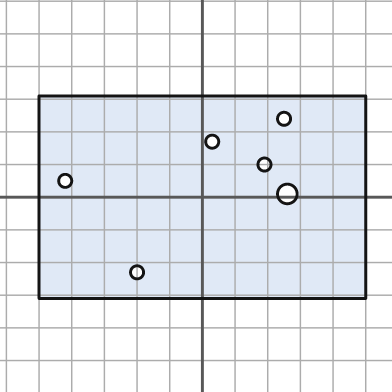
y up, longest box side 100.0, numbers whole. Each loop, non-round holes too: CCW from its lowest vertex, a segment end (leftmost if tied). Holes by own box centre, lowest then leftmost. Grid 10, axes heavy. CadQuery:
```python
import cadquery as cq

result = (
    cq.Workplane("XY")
    .moveTo(-50.0, -31.0)
    .lineTo(50.0, -31.0)
    .lineTo(50.0, 31.0)
    .lineTo(-50.0, 31.0)
    .close()
    .moveTo(-20.0, -23.0)
    .circle(2.0)
    .moveTo(26.0, 1.0)
    .circle(3.0)
    .moveTo(-42.0, 5.0)
    .circle(2.0)
    .moveTo(19.0, 10.0)
    .circle(2.0)
    .moveTo(3.0, 17.0)
    .circle(2.0)
    .moveTo(25.0, 24.0)
    .circle(2.0)
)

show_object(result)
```